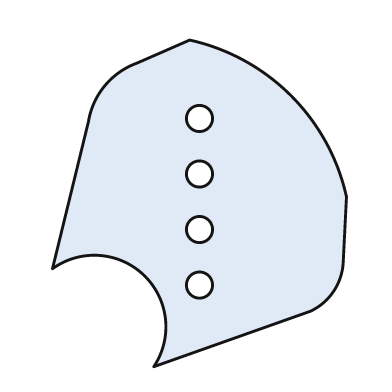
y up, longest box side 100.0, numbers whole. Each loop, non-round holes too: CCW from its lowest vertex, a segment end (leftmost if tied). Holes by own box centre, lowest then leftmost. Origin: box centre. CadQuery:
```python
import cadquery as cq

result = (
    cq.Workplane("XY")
    .moveTo(-14.0, -50.0)
    .lineTo(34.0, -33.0)
    .threePointArc((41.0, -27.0), (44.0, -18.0))
    .lineTo(45.0, 2.0)
    .threePointArc((28.0, 33.0), (-3.0, 50.0))
    .lineTo(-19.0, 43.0)
    .threePointArc((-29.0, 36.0), (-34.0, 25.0))
    .lineTo(-45.0, -20.0)
    .threePointArc((-17.0, -22.0), (-14.0, -50.0))
    .close()
    .moveTo(0.0, -25.0)
    .circle(4.0)
    .moveTo(0.0, -8.0)
    .circle(4.0)
    .moveTo(0.0, 9.0)
    .circle(4.0)
    .moveTo(0.0, 26.0)
    .circle(4.0)
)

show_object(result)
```